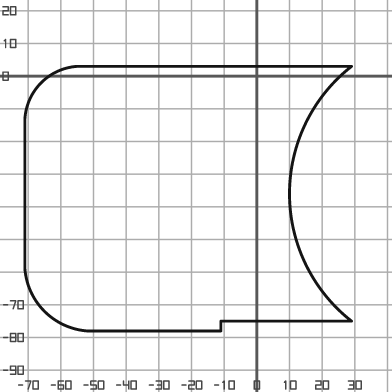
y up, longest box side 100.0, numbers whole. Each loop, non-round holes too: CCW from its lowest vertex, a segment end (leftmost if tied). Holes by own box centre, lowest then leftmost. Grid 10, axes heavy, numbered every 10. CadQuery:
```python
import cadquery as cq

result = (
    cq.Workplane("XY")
    .moveTo(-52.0, -78.0)
    .lineTo(-11.0, -78.0)
    .lineTo(-11.0, -75.0)
    .lineTo(29.0, -75.0)
    .threePointArc((10.0, -36.0), (29.0, 3.0))
    .lineTo(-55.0, 3.0)
    .threePointArc((-66.0, -2.0), (-71.0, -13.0))
    .lineTo(-71.0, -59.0)
    .threePointArc((-65.0, -72.0), (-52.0, -78.0))
    .close()
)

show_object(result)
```